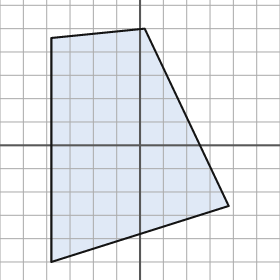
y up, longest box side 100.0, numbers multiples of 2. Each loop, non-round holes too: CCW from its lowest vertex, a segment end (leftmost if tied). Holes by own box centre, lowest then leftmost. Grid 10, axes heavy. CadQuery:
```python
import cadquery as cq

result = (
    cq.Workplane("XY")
    .moveTo(-38.0, -50.0)
    .lineTo(38.0, -26.0)
    .lineTo(2.0, 50.0)
    .lineTo(-38.0, 46.0)
    .close()
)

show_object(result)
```